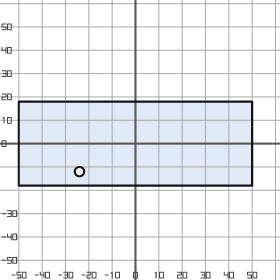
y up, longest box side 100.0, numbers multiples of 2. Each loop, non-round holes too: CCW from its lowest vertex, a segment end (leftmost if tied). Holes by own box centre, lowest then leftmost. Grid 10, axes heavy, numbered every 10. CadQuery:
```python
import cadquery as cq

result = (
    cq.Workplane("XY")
    .moveTo(-50.0, -18.0)
    .lineTo(50.0, -18.0)
    .lineTo(50.0, 18.0)
    .lineTo(-50.0, 18.0)
    .close()
    .moveTo(-24.0, -12.0)
    .circle(2.0)
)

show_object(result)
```